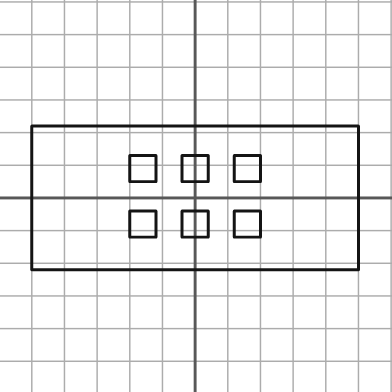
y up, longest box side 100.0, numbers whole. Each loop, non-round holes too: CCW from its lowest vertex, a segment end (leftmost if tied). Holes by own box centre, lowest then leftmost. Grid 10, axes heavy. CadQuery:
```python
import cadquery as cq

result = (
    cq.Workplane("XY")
    .moveTo(-50.0, -22.0)
    .lineTo(50.0, -22.0)
    .lineTo(50.0, 22.0)
    .lineTo(-50.0, 22.0)
    .close()
    .moveTo(-20.0, -12.0)
    .lineTo(-12.0, -12.0)
    .lineTo(-12.0, -4.0)
    .lineTo(-20.0, -4.0)
    .close()
    .moveTo(-4.0, -12.0)
    .lineTo(4.0, -12.0)
    .lineTo(4.0, -4.0)
    .lineTo(-4.0, -4.0)
    .close()
    .moveTo(12.0, -12.0)
    .lineTo(20.0, -12.0)
    .lineTo(20.0, -4.0)
    .lineTo(12.0, -4.0)
    .close()
    .moveTo(-20.0, 5.0)
    .lineTo(-12.0, 5.0)
    .lineTo(-12.0, 13.0)
    .lineTo(-20.0, 13.0)
    .close()
    .moveTo(-4.0, 5.0)
    .lineTo(4.0, 5.0)
    .lineTo(4.0, 13.0)
    .lineTo(-4.0, 13.0)
    .close()
    .moveTo(12.0, 5.0)
    .lineTo(20.0, 5.0)
    .lineTo(20.0, 13.0)
    .lineTo(12.0, 13.0)
    .close()
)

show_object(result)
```